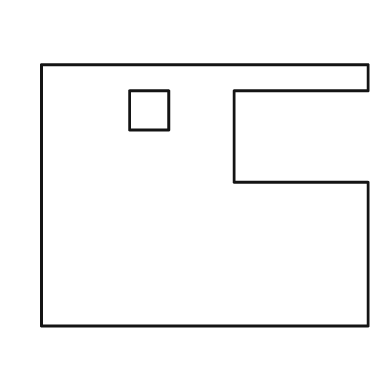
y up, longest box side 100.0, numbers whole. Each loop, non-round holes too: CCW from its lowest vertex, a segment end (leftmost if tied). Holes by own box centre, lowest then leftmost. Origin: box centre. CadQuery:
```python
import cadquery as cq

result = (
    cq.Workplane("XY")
    .moveTo(-50.0, -40.0)
    .lineTo(50.0, -40.0)
    .lineTo(50.0, 4.0)
    .lineTo(9.0, 4.0)
    .lineTo(9.0, 32.0)
    .lineTo(50.0, 32.0)
    .lineTo(50.0, 40.0)
    .lineTo(-50.0, 40.0)
    .close()
    .moveTo(-23.0, 20.0)
    .lineTo(-11.0, 20.0)
    .lineTo(-11.0, 32.0)
    .lineTo(-23.0, 32.0)
    .close()
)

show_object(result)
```